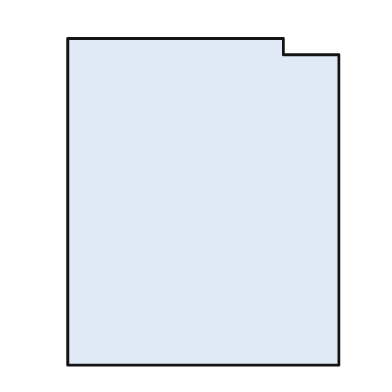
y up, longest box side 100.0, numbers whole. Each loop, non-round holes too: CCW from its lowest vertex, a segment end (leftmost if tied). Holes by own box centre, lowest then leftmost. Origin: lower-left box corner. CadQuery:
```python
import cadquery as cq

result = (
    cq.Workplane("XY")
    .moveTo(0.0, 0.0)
    .lineTo(83.0, 0.0)
    .lineTo(83.0, 95.0)
    .lineTo(66.0, 95.0)
    .lineTo(66.0, 100.0)
    .lineTo(0.0, 100.0)
    .close()
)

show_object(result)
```